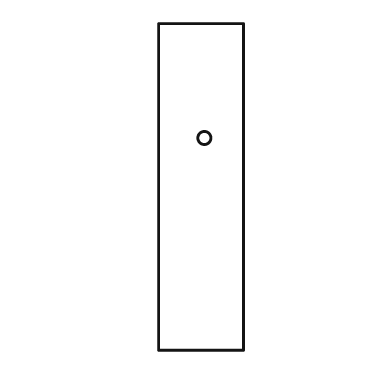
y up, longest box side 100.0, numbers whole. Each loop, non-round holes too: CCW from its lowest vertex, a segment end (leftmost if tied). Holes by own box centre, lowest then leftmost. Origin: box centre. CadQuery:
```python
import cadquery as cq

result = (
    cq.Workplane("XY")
    .moveTo(-13.0, -50.0)
    .lineTo(13.0, -50.0)
    .lineTo(13.0, 50.0)
    .lineTo(-13.0, 50.0)
    .close()
    .moveTo(1.0, 15.0)
    .circle(2.0)
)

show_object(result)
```